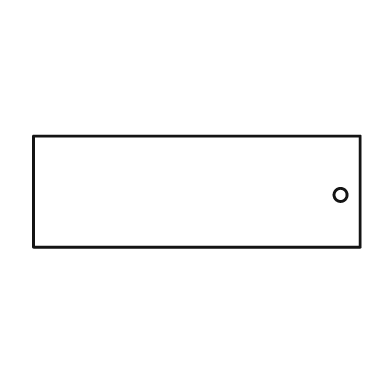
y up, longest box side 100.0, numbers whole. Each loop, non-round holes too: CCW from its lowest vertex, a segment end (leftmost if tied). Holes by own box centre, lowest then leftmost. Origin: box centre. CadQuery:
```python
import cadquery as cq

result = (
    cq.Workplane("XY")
    .moveTo(-50.0, -17.0)
    .lineTo(50.0, -17.0)
    .lineTo(50.0, 17.0)
    .lineTo(-50.0, 17.0)
    .close()
    .moveTo(44.0, -1.0)
    .circle(2.0)
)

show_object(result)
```